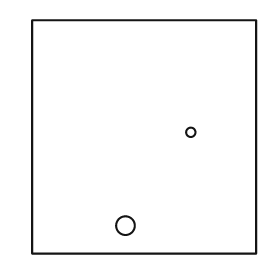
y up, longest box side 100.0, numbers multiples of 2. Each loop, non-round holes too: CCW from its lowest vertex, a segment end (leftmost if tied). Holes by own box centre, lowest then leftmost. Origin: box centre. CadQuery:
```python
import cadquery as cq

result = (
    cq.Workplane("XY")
    .moveTo(-48.0, -50.0)
    .lineTo(48.0, -50.0)
    .lineTo(48.0, 50.0)
    .lineTo(-48.0, 50.0)
    .close()
    .moveTo(-8.0, -38.0)
    .circle(4.0)
    .moveTo(20.0, 2.0)
    .circle(2.0)
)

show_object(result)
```